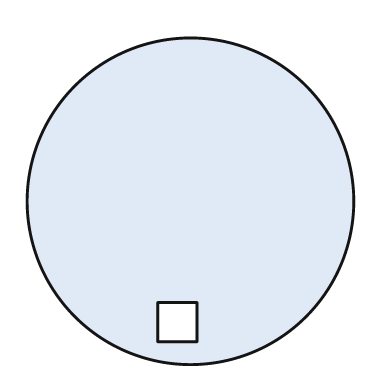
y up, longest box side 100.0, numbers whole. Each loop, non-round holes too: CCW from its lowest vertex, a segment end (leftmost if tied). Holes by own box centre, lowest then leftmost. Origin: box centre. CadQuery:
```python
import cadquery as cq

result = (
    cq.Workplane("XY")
    .moveTo(0.0, 0.0)
    .circle(50.0)
    .moveTo(-10.0, -43.0)
    .lineTo(2.0, -43.0)
    .lineTo(2.0, -31.0)
    .lineTo(-10.0, -31.0)
    .close()
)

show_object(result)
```